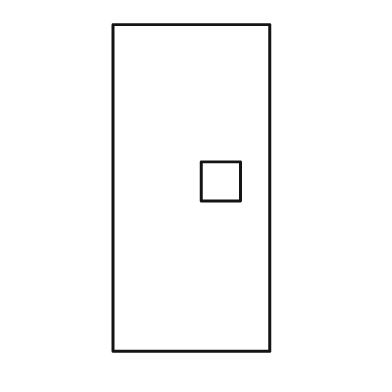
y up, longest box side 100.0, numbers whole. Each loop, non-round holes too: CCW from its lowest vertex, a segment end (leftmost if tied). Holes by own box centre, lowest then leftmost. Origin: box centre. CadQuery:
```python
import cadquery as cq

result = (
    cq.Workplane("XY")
    .moveTo(-24.0, -50.0)
    .lineTo(24.0, -50.0)
    .lineTo(24.0, 50.0)
    .lineTo(-24.0, 50.0)
    .close()
    .moveTo(3.0, -4.0)
    .lineTo(15.0, -4.0)
    .lineTo(15.0, 8.0)
    .lineTo(3.0, 8.0)
    .close()
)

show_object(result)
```